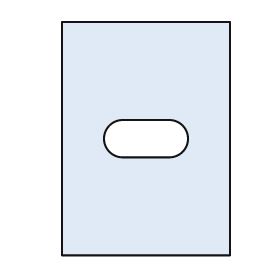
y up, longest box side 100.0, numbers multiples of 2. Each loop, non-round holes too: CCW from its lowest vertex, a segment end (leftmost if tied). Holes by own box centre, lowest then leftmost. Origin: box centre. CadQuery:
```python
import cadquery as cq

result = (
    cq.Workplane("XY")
    .moveTo(-36.0, -50.0)
    .lineTo(36.0, -50.0)
    .lineTo(36.0, 50.0)
    .lineTo(-36.0, 50.0)
    .close()
    .moveTo(-10.0, -8.0)
    .lineTo(10.0, -8.0)
    .threePointArc((18.0, 0.0), (10.0, 8.0))
    .lineTo(-10.0, 8.0)
    .threePointArc((-18.0, 0.0), (-10.0, -8.0))
    .close()
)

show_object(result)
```